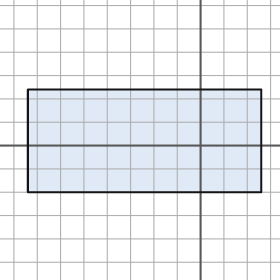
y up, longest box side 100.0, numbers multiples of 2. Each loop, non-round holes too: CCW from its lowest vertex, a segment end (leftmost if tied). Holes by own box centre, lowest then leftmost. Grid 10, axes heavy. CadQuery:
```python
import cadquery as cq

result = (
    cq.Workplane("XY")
    .moveTo(-74.0, -20.0)
    .lineTo(26.0, -20.0)
    .lineTo(26.0, 24.0)
    .lineTo(-74.0, 24.0)
    .close()
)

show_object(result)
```